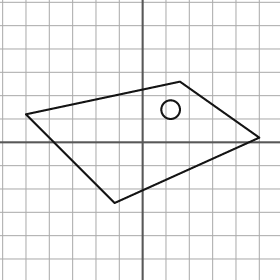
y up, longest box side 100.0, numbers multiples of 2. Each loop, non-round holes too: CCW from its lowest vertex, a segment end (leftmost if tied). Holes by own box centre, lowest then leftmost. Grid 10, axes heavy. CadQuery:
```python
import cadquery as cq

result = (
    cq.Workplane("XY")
    .moveTo(-12.0, -26.0)
    .lineTo(50.0, 2.0)
    .lineTo(16.0, 26.0)
    .lineTo(-50.0, 12.0)
    .close()
    .moveTo(12.0, 14.0)
    .circle(4.0)
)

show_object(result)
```